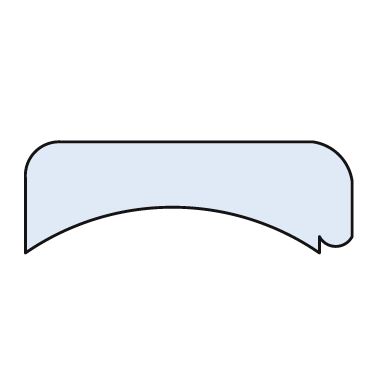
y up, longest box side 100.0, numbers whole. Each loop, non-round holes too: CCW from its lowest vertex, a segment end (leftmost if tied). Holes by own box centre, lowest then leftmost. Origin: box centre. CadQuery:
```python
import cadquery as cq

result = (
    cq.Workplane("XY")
    .moveTo(-50.0, -17.0)
    .threePointArc((-5.0, -3.0), (40.0, -17.0))
    .lineTo(40.0, -12.0)
    .threePointArc((45.0, -15.0), (50.0, -12.0))
    .lineTo(50.0, 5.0)
    .threePointArc((46.0, 13.0), (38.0, 17.0))
    .lineTo(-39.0, 17.0)
    .threePointArc((-47.0, 14.0), (-50.0, 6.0))
    .close()
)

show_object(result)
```